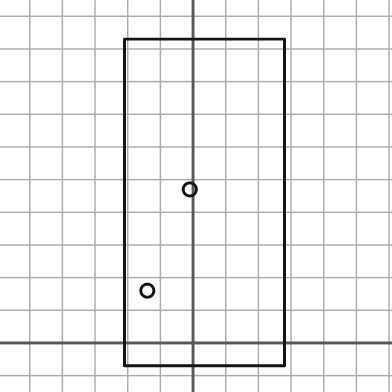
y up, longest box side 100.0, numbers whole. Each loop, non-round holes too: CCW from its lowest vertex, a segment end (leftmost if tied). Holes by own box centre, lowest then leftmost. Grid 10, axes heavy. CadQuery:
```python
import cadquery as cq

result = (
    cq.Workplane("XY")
    .moveTo(-21.0, -7.0)
    .lineTo(28.0, -7.0)
    .lineTo(28.0, 93.0)
    .lineTo(-21.0, 93.0)
    .close()
    .moveTo(-14.0, 16.0)
    .circle(2.0)
    .moveTo(-1.0, 47.0)
    .circle(2.0)
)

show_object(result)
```